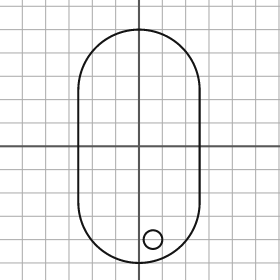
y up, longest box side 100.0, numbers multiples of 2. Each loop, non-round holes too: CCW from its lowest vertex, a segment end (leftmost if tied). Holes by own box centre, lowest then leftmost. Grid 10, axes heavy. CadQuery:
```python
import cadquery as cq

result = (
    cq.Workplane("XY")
    .moveTo(-26.0, -24.0)
    .threePointArc((0.0, -50.0), (26.0, -24.0))
    .lineTo(26.0, 24.0)
    .threePointArc((0.0, 50.0), (-26.0, 24.0))
    .close()
    .moveTo(6.0, -40.0)
    .circle(4.0)
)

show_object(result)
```